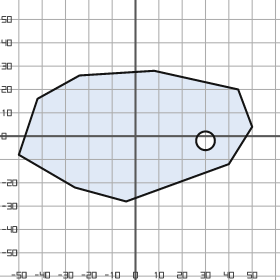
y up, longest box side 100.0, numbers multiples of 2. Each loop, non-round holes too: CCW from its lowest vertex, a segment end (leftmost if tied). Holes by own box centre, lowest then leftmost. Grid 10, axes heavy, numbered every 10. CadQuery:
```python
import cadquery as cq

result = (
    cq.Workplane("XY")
    .moveTo(-4.0, -28.0)
    .lineTo(40.0, -12.0)
    .lineTo(50.0, 4.0)
    .lineTo(44.0, 20.0)
    .lineTo(8.0, 28.0)
    .lineTo(-24.0, 26.0)
    .lineTo(-42.0, 16.0)
    .lineTo(-50.0, -8.0)
    .lineTo(-26.0, -22.0)
    .close()
    .moveTo(30.0, -2.0)
    .circle(4.0)
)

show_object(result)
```